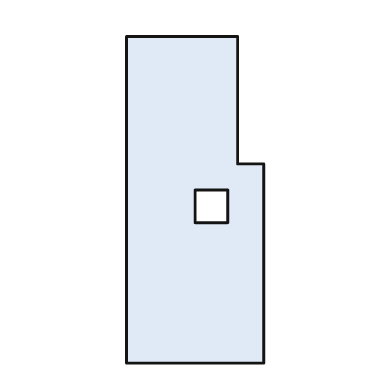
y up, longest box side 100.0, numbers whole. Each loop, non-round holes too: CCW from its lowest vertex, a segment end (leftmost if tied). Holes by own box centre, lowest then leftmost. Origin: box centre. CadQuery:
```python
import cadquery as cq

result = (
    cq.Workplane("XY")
    .moveTo(-21.0, -50.0)
    .lineTo(21.0, -50.0)
    .lineTo(21.0, 11.0)
    .lineTo(13.0, 11.0)
    .lineTo(13.0, 50.0)
    .lineTo(-21.0, 50.0)
    .close()
    .moveTo(0.0, -7.0)
    .lineTo(10.0, -7.0)
    .lineTo(10.0, 3.0)
    .lineTo(0.0, 3.0)
    .close()
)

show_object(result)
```